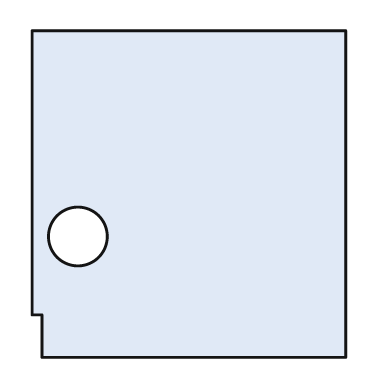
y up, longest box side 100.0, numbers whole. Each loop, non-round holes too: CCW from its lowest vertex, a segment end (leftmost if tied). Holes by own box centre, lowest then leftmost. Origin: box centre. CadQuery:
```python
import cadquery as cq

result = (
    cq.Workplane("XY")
    .moveTo(-45.0, -50.0)
    .lineTo(48.0, -50.0)
    .lineTo(48.0, 50.0)
    .lineTo(-48.0, 50.0)
    .lineTo(-48.0, -37.0)
    .lineTo(-45.0, -37.0)
    .close()
    .moveTo(-34.0, -13.0)
    .circle(9.0)
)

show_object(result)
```